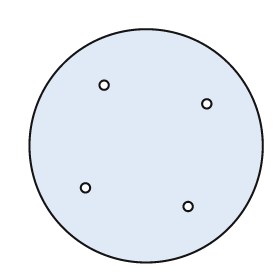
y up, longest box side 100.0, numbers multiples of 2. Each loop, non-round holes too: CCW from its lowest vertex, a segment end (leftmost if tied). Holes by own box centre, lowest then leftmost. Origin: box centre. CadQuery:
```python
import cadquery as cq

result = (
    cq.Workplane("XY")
    .moveTo(0.0, 0.0)
    .circle(50.0)
    .moveTo(18.0, -26.0)
    .circle(2.0)
    .moveTo(-26.0, -18.0)
    .circle(2.0)
    .moveTo(26.0, 18.0)
    .circle(2.0)
    .moveTo(-18.0, 26.0)
    .circle(2.0)
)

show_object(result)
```